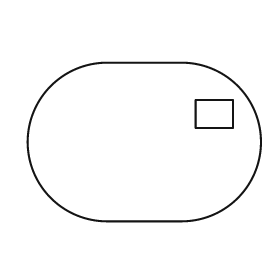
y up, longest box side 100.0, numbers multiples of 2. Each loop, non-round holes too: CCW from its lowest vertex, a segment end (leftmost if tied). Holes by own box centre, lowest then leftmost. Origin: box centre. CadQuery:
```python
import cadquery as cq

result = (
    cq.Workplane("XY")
    .moveTo(-16.0, -34.0)
    .lineTo(16.0, -34.0)
    .threePointArc((50.0, 0.0), (16.0, 34.0))
    .lineTo(-16.0, 34.0)
    .threePointArc((-50.0, 0.0), (-16.0, -34.0))
    .close()
    .moveTo(22.0, 6.0)
    .lineTo(38.0, 6.0)
    .lineTo(38.0, 18.0)
    .lineTo(22.0, 18.0)
    .close()
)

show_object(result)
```